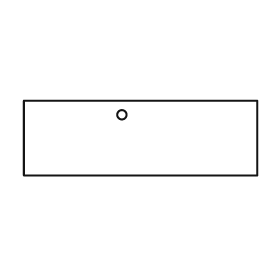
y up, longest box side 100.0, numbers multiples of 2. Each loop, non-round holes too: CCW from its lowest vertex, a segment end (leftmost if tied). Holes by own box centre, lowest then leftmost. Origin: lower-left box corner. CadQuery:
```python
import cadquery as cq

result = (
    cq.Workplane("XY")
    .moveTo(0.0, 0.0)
    .lineTo(100.0, 0.0)
    .lineTo(100.0, 32.0)
    .lineTo(0.0, 32.0)
    .close()
    .moveTo(42.0, 26.0)
    .circle(2.0)
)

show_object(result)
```